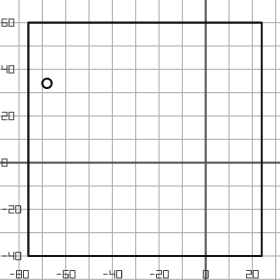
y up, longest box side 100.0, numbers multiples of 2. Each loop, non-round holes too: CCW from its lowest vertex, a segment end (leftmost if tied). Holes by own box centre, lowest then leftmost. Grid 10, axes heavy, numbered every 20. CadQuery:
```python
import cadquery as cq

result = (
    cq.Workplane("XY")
    .moveTo(-76.0, -40.0)
    .lineTo(24.0, -40.0)
    .lineTo(24.0, 60.0)
    .lineTo(-76.0, 60.0)
    .close()
    .moveTo(-68.0, 34.0)
    .circle(2.0)
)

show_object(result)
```